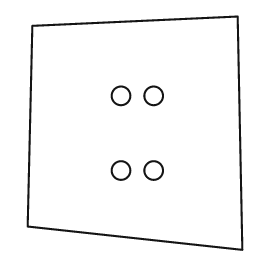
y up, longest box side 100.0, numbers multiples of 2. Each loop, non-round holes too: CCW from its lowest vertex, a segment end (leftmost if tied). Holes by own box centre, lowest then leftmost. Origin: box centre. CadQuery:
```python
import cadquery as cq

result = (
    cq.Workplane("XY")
    .moveTo(46.0, -50.0)
    .lineTo(44.0, 50.0)
    .lineTo(-44.0, 46.0)
    .lineTo(-46.0, -40.0)
    .close()
    .moveTo(-6.0, -16.0)
    .circle(4.0)
    .moveTo(8.0, -16.0)
    .circle(4.0)
    .moveTo(-6.0, 16.0)
    .circle(4.0)
    .moveTo(8.0, 16.0)
    .circle(4.0)
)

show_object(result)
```